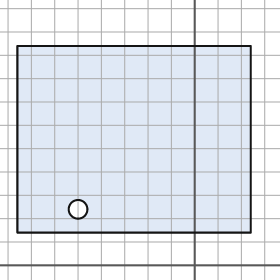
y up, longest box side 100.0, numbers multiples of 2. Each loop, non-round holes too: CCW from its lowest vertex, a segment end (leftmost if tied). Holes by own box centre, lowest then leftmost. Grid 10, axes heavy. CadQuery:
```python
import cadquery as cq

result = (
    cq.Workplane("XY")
    .moveTo(-76.0, 14.0)
    .lineTo(24.0, 14.0)
    .lineTo(24.0, 94.0)
    .lineTo(-76.0, 94.0)
    .close()
    .moveTo(-50.0, 24.0)
    .circle(4.0)
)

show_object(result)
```